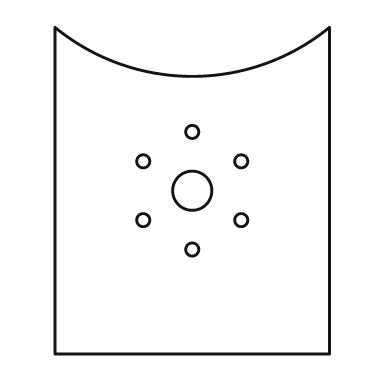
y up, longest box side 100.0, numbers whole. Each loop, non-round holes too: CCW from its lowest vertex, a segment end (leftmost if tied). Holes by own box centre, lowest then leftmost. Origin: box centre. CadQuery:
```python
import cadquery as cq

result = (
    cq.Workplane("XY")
    .moveTo(-42.0, -50.0)
    .lineTo(42.0, -50.0)
    .lineTo(42.0, 50.0)
    .threePointArc((0.0, 35.0), (-42.0, 50.0))
    .close()
    .moveTo(0.0, -18.0)
    .circle(2.0)
    .moveTo(-15.0, -9.0)
    .circle(2.0)
    .moveTo(15.0, -9.0)
    .circle(2.0)
    .moveTo(0.0, 0.0)
    .circle(6.0)
    .moveTo(-15.0, 9.0)
    .circle(2.0)
    .moveTo(15.0, 9.0)
    .circle(2.0)
    .moveTo(0.0, 18.0)
    .circle(2.0)
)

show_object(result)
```